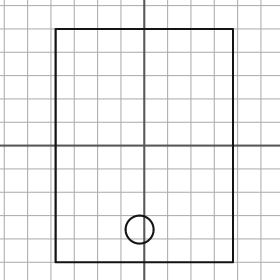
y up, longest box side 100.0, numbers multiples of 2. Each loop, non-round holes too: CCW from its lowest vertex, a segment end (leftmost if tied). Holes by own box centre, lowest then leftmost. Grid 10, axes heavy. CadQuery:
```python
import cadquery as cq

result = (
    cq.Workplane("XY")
    .moveTo(-38.0, -50.0)
    .lineTo(38.0, -50.0)
    .lineTo(38.0, 50.0)
    .lineTo(-38.0, 50.0)
    .close()
    .moveTo(-2.0, -36.0)
    .circle(6.0)
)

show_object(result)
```